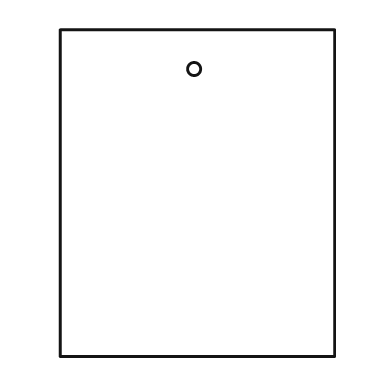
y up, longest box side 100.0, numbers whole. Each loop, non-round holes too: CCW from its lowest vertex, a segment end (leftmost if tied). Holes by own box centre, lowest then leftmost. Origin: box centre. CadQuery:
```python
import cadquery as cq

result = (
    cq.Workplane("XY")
    .moveTo(-42.0, -50.0)
    .lineTo(42.0, -50.0)
    .lineTo(42.0, 50.0)
    .lineTo(-42.0, 50.0)
    .close()
    .moveTo(-1.0, 38.0)
    .circle(2.0)
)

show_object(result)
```